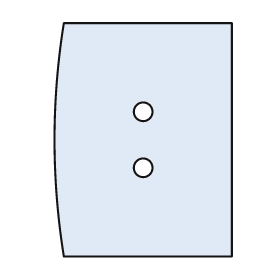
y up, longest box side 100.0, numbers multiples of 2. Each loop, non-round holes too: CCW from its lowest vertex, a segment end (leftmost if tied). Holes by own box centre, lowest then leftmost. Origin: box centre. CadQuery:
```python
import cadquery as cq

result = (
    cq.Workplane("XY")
    .moveTo(-34.0, -50.0)
    .lineTo(38.0, -50.0)
    .lineTo(38.0, 50.0)
    .lineTo(-34.0, 50.0)
    .threePointArc((-38.0, 0.0), (-34.0, -50.0))
    .close()
    .moveTo(0.0, -12.0)
    .circle(4.0)
    .moveTo(0.0, 12.0)
    .circle(4.0)
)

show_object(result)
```